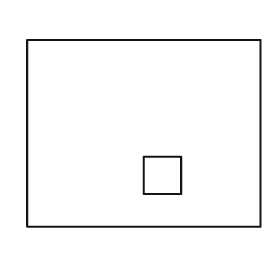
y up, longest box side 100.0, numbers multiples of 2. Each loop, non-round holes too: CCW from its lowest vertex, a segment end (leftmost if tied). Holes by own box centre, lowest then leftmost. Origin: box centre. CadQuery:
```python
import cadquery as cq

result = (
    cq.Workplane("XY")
    .moveTo(-50.0, -40.0)
    .lineTo(50.0, -40.0)
    .lineTo(50.0, 40.0)
    .lineTo(-50.0, 40.0)
    .close()
    .moveTo(0.0, -26.0)
    .lineTo(16.0, -26.0)
    .lineTo(16.0, -10.0)
    .lineTo(0.0, -10.0)
    .close()
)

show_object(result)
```